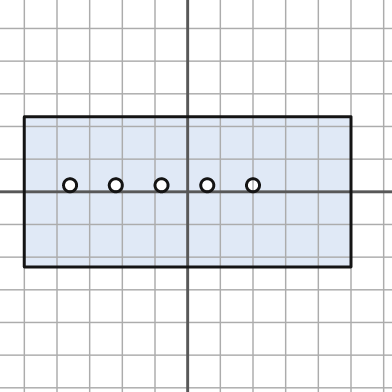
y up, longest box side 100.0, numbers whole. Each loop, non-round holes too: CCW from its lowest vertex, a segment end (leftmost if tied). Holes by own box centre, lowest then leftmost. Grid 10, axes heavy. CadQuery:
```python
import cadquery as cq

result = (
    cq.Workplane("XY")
    .moveTo(-50.0, -23.0)
    .lineTo(50.0, -23.0)
    .lineTo(50.0, 23.0)
    .lineTo(-50.0, 23.0)
    .close()
    .moveTo(-36.0, 2.0)
    .circle(2.0)
    .moveTo(-22.0, 2.0)
    .circle(2.0)
    .moveTo(-8.0, 2.0)
    .circle(2.0)
    .moveTo(6.0, 2.0)
    .circle(2.0)
    .moveTo(20.0, 2.0)
    .circle(2.0)
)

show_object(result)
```